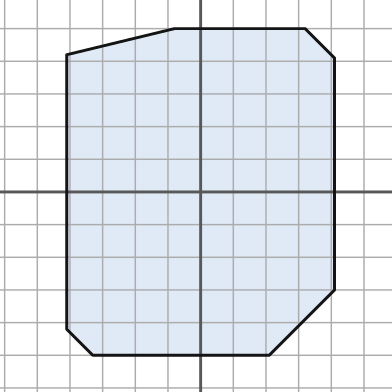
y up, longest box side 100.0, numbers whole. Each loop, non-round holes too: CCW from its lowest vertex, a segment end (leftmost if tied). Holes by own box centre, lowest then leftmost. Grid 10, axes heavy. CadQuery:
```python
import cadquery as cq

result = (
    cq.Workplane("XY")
    .moveTo(-33.0, -50.0)
    .lineTo(21.0, -50.0)
    .lineTo(41.0, -30.0)
    .lineTo(41.0, 41.0)
    .lineTo(32.0, 50.0)
    .lineTo(-8.0, 50.0)
    .lineTo(-41.0, 42.0)
    .lineTo(-41.0, -42.0)
    .close()
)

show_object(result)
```